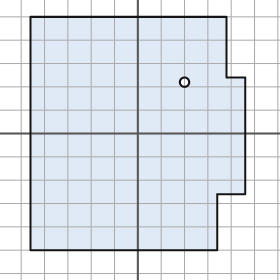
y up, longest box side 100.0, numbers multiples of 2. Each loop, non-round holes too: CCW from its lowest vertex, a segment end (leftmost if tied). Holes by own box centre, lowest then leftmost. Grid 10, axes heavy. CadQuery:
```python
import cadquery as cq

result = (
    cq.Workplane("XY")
    .moveTo(-46.0, -50.0)
    .lineTo(34.0, -50.0)
    .lineTo(34.0, -26.0)
    .lineTo(46.0, -26.0)
    .lineTo(46.0, 24.0)
    .lineTo(38.0, 24.0)
    .lineTo(38.0, 50.0)
    .lineTo(-46.0, 50.0)
    .close()
    .moveTo(20.0, 22.0)
    .circle(2.0)
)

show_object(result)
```